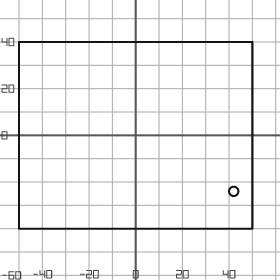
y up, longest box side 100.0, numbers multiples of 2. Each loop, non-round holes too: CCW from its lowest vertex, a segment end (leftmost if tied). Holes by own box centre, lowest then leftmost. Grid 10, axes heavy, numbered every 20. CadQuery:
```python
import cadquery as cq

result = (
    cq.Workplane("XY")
    .moveTo(-50.0, -40.0)
    .lineTo(50.0, -40.0)
    .lineTo(50.0, 40.0)
    .lineTo(-50.0, 40.0)
    .close()
    .moveTo(42.0, -24.0)
    .circle(2.0)
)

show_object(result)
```